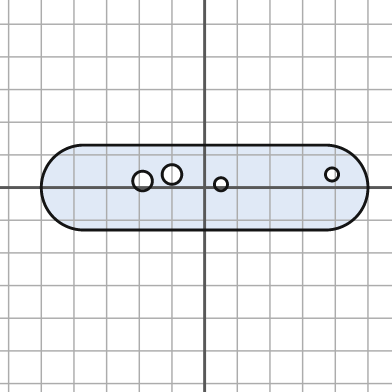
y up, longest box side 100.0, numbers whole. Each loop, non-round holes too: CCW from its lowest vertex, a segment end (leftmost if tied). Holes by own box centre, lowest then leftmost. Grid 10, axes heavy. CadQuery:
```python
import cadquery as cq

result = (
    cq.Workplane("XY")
    .moveTo(-37.0, -13.0)
    .lineTo(37.0, -13.0)
    .threePointArc((50.0, 0.0), (37.0, 13.0))
    .lineTo(-37.0, 13.0)
    .threePointArc((-50.0, 0.0), (-37.0, -13.0))
    .close()
    .moveTo(5.0, 1.0)
    .circle(2.0)
    .moveTo(-19.0, 2.0)
    .circle(3.0)
    .moveTo(-10.0, 4.0)
    .circle(3.0)
    .moveTo(39.0, 4.0)
    .circle(2.0)
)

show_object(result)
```